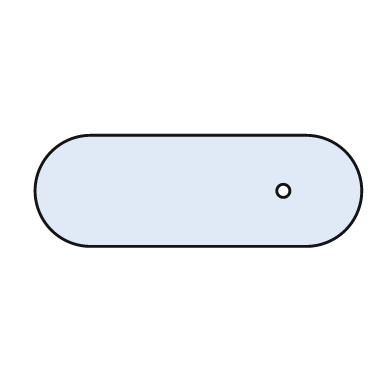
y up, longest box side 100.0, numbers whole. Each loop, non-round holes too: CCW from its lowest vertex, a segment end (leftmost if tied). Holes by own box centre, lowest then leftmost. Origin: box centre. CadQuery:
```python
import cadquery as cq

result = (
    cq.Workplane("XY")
    .moveTo(-33.0, -17.0)
    .lineTo(33.0, -17.0)
    .threePointArc((50.0, 0.0), (33.0, 17.0))
    .lineTo(-33.0, 17.0)
    .threePointArc((-50.0, 0.0), (-33.0, -17.0))
    .close()
    .moveTo(26.0, 0.0)
    .circle(2.0)
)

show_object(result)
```